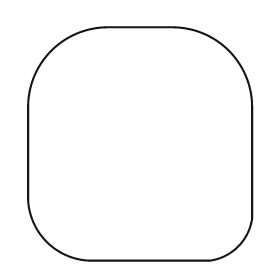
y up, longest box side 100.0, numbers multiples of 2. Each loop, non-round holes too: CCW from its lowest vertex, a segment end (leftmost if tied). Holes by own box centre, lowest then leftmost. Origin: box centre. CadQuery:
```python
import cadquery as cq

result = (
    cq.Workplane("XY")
    .moveTo(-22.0, -50.0)
    .lineTo(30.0, -50.0)
    .threePointArc((42.0, -44.0), (48.0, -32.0))
    .lineTo(48.0, 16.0)
    .threePointArc((38.0, 40.0), (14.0, 50.0))
    .lineTo(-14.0, 50.0)
    .threePointArc((-38.0, 40.0), (-48.0, 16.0))
    .lineTo(-48.0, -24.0)
    .threePointArc((-40.0, -42.0), (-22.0, -50.0))
    .close()
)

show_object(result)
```